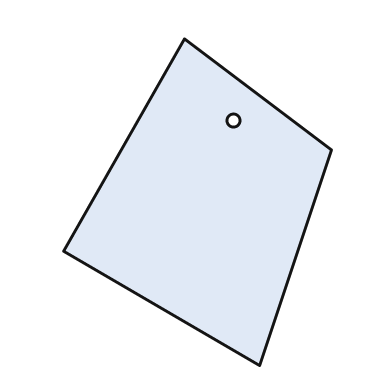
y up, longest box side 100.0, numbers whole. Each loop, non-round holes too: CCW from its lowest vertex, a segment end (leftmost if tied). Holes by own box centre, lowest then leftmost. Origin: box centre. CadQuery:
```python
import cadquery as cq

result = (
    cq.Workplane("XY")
    .moveTo(19.0, -50.0)
    .lineTo(41.0, 16.0)
    .lineTo(-4.0, 50.0)
    .lineTo(-41.0, -15.0)
    .close()
    .moveTo(11.0, 25.0)
    .circle(2.0)
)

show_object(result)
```